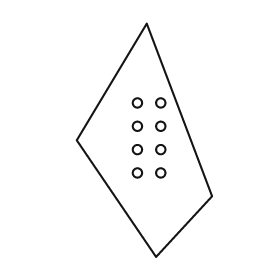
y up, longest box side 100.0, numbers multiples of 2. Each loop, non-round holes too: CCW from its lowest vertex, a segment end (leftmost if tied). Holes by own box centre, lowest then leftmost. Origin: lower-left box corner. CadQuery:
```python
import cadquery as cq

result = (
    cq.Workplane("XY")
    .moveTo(34.0, 0.0)
    .lineTo(58.0, 26.0)
    .lineTo(30.0, 100.0)
    .lineTo(0.0, 50.0)
    .close()
    .moveTo(26.0, 36.0)
    .circle(2.0)
    .moveTo(36.0, 36.0)
    .circle(2.0)
    .moveTo(26.0, 46.0)
    .circle(2.0)
    .moveTo(36.0, 46.0)
    .circle(2.0)
    .moveTo(26.0, 56.0)
    .circle(2.0)
    .moveTo(36.0, 56.0)
    .circle(2.0)
    .moveTo(26.0, 66.0)
    .circle(2.0)
    .moveTo(36.0, 66.0)
    .circle(2.0)
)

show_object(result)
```